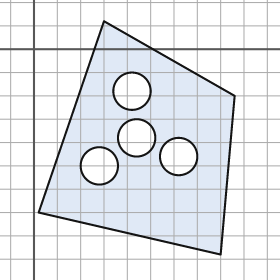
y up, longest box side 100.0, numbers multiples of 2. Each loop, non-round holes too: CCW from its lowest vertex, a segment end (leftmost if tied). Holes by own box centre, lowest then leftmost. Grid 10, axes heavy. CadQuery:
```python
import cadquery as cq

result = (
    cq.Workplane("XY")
    .moveTo(80.0, -88.0)
    .lineTo(86.0, -20.0)
    .lineTo(30.0, 12.0)
    .lineTo(2.0, -70.0)
    .close()
    .moveTo(28.0, -50.0)
    .circle(8.0)
    .moveTo(62.0, -46.0)
    .circle(8.0)
    .moveTo(44.0, -38.0)
    .circle(8.0)
    .moveTo(42.0, -18.0)
    .circle(8.0)
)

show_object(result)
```